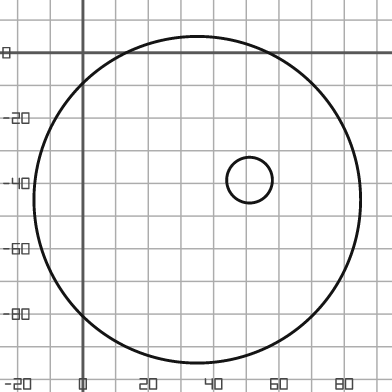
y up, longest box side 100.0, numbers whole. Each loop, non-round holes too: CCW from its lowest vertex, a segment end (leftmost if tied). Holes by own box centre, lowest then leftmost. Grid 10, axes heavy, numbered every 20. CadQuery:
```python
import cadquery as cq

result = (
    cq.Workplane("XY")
    .moveTo(35.0, -45.0)
    .circle(50.0)
    .moveTo(51.0, -39.0)
    .circle(7.0)
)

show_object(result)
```